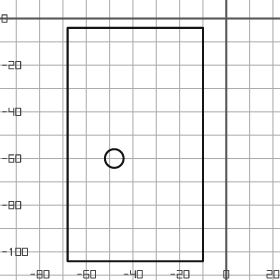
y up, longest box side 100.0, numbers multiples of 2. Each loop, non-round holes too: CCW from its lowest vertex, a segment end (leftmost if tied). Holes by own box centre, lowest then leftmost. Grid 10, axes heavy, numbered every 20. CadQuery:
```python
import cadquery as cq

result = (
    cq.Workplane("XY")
    .moveTo(-68.0, -104.0)
    .lineTo(-10.0, -104.0)
    .lineTo(-10.0, -4.0)
    .lineTo(-68.0, -4.0)
    .close()
    .moveTo(-48.0, -60.0)
    .circle(4.0)
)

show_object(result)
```